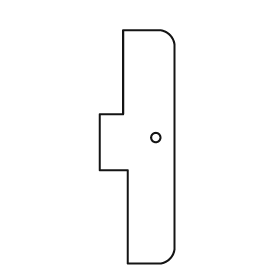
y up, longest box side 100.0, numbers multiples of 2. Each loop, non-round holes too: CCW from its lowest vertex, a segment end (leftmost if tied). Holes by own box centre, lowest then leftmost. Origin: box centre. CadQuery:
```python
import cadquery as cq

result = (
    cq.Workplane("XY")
    .moveTo(-4.0, -50.0)
    .lineTo(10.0, -50.0)
    .threePointArc((14.0, -48.0), (16.0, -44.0))
    .lineTo(16.0, 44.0)
    .threePointArc((14.0, 48.0), (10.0, 50.0))
    .lineTo(-6.0, 50.0)
    .lineTo(-6.0, 14.0)
    .lineTo(-16.0, 14.0)
    .lineTo(-16.0, -10.0)
    .lineTo(-4.0, -10.0)
    .close()
    .moveTo(8.0, 4.0)
    .circle(2.0)
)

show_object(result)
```